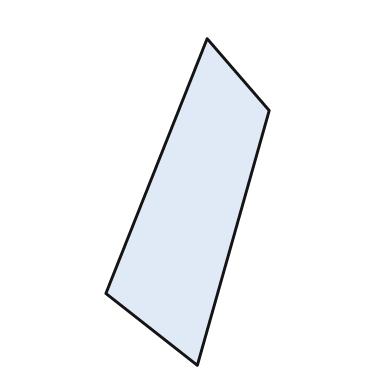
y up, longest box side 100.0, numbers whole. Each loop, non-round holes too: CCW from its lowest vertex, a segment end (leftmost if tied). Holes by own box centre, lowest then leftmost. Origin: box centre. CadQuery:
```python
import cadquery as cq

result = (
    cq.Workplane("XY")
    .moveTo(3.0, -50.0)
    .lineTo(25.0, 28.0)
    .lineTo(6.0, 50.0)
    .lineTo(-25.0, -28.0)
    .close()
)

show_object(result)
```